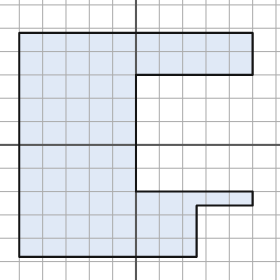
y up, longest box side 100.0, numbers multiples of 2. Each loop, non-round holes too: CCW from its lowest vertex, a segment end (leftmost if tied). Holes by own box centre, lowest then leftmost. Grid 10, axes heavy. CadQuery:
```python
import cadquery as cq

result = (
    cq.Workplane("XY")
    .moveTo(-50.0, -48.0)
    .lineTo(26.0, -48.0)
    .lineTo(26.0, -26.0)
    .lineTo(50.0, -26.0)
    .lineTo(50.0, -20.0)
    .lineTo(0.0, -20.0)
    .lineTo(0.0, 30.0)
    .lineTo(50.0, 30.0)
    .lineTo(50.0, 48.0)
    .lineTo(-50.0, 48.0)
    .close()
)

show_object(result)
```